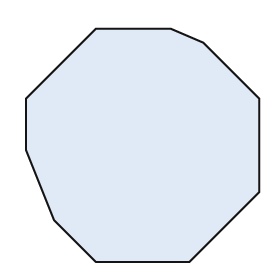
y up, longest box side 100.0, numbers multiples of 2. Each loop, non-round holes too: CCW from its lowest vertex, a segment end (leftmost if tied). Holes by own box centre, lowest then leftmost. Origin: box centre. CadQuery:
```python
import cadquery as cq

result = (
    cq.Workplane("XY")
    .moveTo(-20.0, -50.0)
    .lineTo(20.0, -50.0)
    .lineTo(50.0, -20.0)
    .lineTo(50.0, 20.0)
    .lineTo(26.0, 44.0)
    .lineTo(12.0, 50.0)
    .lineTo(-20.0, 50.0)
    .lineTo(-50.0, 20.0)
    .lineTo(-50.0, -2.0)
    .lineTo(-38.0, -32.0)
    .close()
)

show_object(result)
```